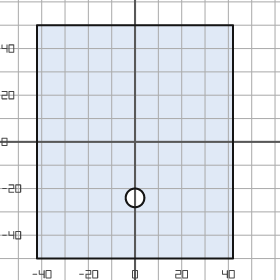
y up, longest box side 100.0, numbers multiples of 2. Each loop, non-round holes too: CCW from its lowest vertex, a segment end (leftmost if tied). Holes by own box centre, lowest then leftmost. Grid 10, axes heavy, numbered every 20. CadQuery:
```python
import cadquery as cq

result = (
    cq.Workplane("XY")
    .moveTo(-42.0, -50.0)
    .lineTo(42.0, -50.0)
    .lineTo(42.0, 50.0)
    .lineTo(-42.0, 50.0)
    .close()
    .moveTo(0.0, -24.0)
    .circle(4.0)
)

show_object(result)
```